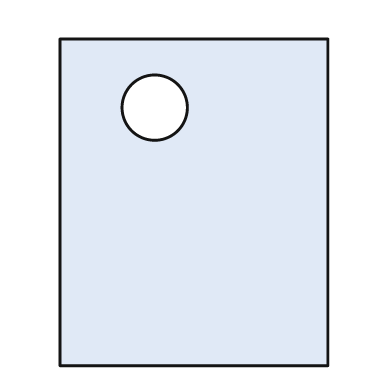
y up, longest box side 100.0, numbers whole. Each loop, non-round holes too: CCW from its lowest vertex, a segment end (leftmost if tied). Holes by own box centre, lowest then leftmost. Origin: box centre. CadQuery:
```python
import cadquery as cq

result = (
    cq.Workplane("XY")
    .moveTo(-41.0, -50.0)
    .lineTo(41.0, -50.0)
    .lineTo(41.0, 50.0)
    .lineTo(-41.0, 50.0)
    .close()
    .moveTo(-12.0, 29.0)
    .circle(10.0)
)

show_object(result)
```